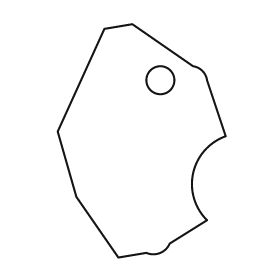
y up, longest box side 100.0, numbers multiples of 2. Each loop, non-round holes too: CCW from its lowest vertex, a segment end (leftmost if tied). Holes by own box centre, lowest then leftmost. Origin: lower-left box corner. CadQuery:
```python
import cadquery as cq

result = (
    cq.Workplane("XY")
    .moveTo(26.0, 0.0)
    .lineTo(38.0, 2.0)
    .threePointArc((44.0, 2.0), (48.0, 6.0))
    .lineTo(64.0, 16.0)
    .threePointArc((58.0, 36.0), (72.0, 52.0))
    .lineTo(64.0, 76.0)
    .threePointArc((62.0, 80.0), (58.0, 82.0))
    .lineTo(32.0, 100.0)
    .lineTo(20.0, 98.0)
    .lineTo(0.0, 54.0)
    .lineTo(8.0, 26.0)
    .close()
    .moveTo(44.0, 76.0)
    .circle(6.0)
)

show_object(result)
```